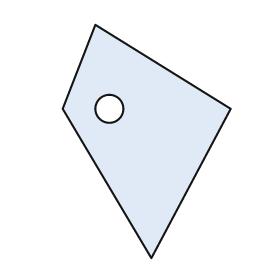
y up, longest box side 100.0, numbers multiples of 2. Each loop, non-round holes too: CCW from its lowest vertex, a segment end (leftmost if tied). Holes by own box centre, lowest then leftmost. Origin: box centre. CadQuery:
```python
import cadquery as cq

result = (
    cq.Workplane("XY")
    .moveTo(2.0, -50.0)
    .lineTo(36.0, 14.0)
    .lineTo(-22.0, 50.0)
    .lineTo(-36.0, 14.0)
    .close()
    .moveTo(-16.0, 14.0)
    .circle(6.0)
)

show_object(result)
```